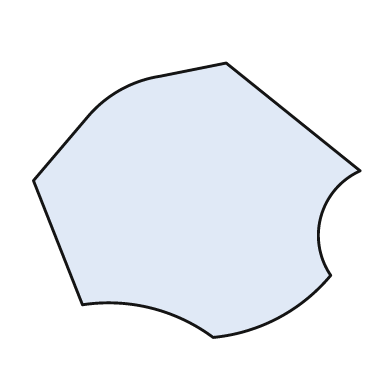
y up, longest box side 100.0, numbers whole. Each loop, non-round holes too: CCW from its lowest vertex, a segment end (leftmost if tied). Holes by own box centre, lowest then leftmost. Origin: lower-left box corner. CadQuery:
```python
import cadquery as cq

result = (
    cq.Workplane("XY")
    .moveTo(55.0, 0.0)
    .threePointArc((75.0, 6.0), (91.0, 19.0))
    .threePointArc((88.0, 37.0), (100.0, 51.0))
    .lineTo(59.0, 84.0)
    .lineTo(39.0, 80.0)
    .threePointArc((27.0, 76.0), (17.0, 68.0))
    .lineTo(0.0, 48.0)
    .lineTo(15.0, 10.0)
    .threePointArc((36.0, 9.0), (55.0, 0.0))
    .close()
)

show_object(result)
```